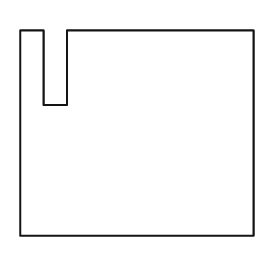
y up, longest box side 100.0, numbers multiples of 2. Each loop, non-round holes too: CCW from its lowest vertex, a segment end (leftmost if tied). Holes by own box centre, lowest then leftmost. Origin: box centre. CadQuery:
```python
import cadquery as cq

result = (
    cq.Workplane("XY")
    .moveTo(-50.0, -44.0)
    .lineTo(50.0, -44.0)
    .lineTo(50.0, 44.0)
    .lineTo(-30.0, 44.0)
    .lineTo(-30.0, 12.0)
    .lineTo(-40.0, 12.0)
    .lineTo(-40.0, 44.0)
    .lineTo(-50.0, 44.0)
    .close()
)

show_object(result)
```